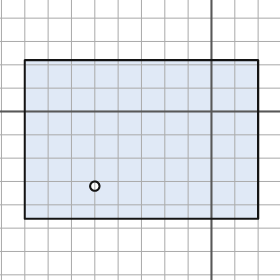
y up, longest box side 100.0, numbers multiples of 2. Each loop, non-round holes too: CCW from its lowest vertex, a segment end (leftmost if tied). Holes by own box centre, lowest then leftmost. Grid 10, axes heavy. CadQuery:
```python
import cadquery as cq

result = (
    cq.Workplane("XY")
    .moveTo(-80.0, -46.0)
    .lineTo(20.0, -46.0)
    .lineTo(20.0, 22.0)
    .lineTo(-80.0, 22.0)
    .close()
    .moveTo(-50.0, -32.0)
    .circle(2.0)
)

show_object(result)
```